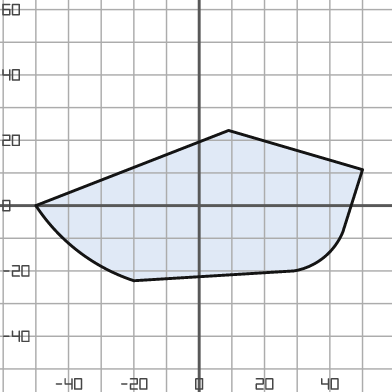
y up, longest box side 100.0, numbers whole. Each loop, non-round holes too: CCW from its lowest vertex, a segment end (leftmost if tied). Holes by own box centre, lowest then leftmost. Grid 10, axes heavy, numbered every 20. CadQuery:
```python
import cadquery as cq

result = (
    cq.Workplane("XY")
    .moveTo(-20.0, -23.0)
    .lineTo(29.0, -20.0)
    .threePointArc((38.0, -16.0), (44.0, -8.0))
    .lineTo(50.0, 11.0)
    .lineTo(9.0, 23.0)
    .lineTo(-50.0, 0.0)
    .threePointArc((-37.0, -14.0), (-20.0, -23.0))
    .close()
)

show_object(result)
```